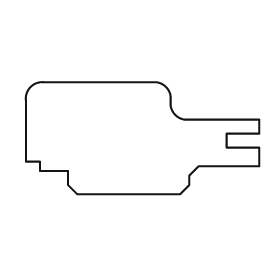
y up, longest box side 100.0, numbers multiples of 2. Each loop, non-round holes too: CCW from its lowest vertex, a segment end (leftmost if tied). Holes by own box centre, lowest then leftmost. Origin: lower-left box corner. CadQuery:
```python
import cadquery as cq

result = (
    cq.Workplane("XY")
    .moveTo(22.0, 0.0)
    .lineTo(66.0, 0.0)
    .lineTo(70.0, 4.0)
    .lineTo(70.0, 8.0)
    .lineTo(74.0, 12.0)
    .lineTo(100.0, 12.0)
    .lineTo(100.0, 20.0)
    .lineTo(86.0, 20.0)
    .lineTo(86.0, 26.0)
    .lineTo(100.0, 26.0)
    .lineTo(100.0, 32.0)
    .lineTo(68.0, 32.0)
    .threePointArc((64.0, 34.0), (62.0, 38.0))
    .lineTo(62.0, 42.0)
    .threePointArc((60.0, 46.0), (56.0, 48.0))
    .lineTo(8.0, 48.0)
    .threePointArc((2.0, 46.0), (0.0, 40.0))
    .lineTo(0.0, 14.0)
    .lineTo(6.0, 14.0)
    .lineTo(6.0, 10.0)
    .lineTo(18.0, 10.0)
    .lineTo(18.0, 4.0)
    .close()
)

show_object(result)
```